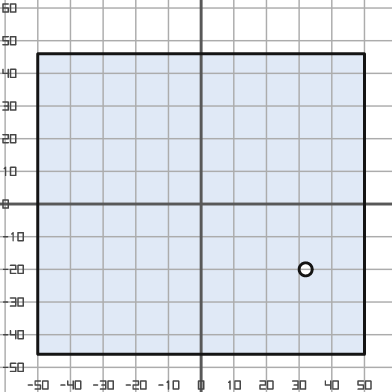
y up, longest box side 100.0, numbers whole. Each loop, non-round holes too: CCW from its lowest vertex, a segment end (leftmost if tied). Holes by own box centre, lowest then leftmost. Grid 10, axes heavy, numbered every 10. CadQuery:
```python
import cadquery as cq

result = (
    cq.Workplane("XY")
    .moveTo(-50.0, -46.0)
    .lineTo(50.0, -46.0)
    .lineTo(50.0, 46.0)
    .lineTo(-50.0, 46.0)
    .close()
    .moveTo(32.0, -20.0)
    .circle(2.0)
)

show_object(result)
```